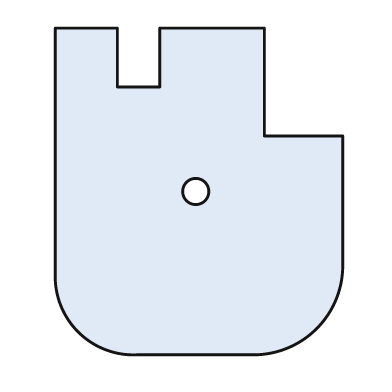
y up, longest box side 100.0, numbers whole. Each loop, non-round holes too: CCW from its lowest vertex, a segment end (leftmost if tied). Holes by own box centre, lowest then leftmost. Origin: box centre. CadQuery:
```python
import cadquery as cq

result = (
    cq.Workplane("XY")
    .moveTo(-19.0, -50.0)
    .lineTo(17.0, -50.0)
    .threePointArc((36.0, -42.0), (44.0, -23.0))
    .lineTo(44.0, 17.0)
    .lineTo(20.0, 17.0)
    .lineTo(20.0, 50.0)
    .lineTo(-12.0, 50.0)
    .lineTo(-12.0, 32.0)
    .lineTo(-25.0, 32.0)
    .lineTo(-25.0, 50.0)
    .lineTo(-44.0, 50.0)
    .lineTo(-44.0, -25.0)
    .threePointArc((-37.0, -43.0), (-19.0, -50.0))
    .close()
    .moveTo(-1.0, 0.0)
    .circle(4.0)
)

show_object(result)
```